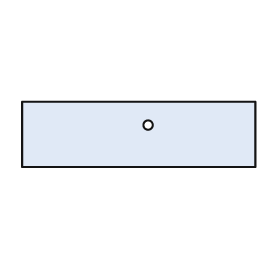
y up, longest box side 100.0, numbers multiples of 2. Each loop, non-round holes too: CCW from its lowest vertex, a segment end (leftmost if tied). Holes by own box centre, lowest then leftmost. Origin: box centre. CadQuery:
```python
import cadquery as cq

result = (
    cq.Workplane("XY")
    .moveTo(-50.0, -14.0)
    .lineTo(50.0, -14.0)
    .lineTo(50.0, 14.0)
    .lineTo(-50.0, 14.0)
    .close()
    .moveTo(4.0, 4.0)
    .circle(2.0)
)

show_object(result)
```